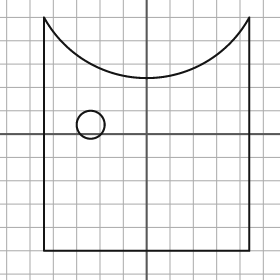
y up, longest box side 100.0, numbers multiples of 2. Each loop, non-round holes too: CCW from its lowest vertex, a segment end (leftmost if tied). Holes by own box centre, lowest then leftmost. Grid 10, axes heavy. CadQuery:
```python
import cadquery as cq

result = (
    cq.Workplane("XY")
    .moveTo(-44.0, -50.0)
    .lineTo(44.0, -50.0)
    .lineTo(44.0, 50.0)
    .threePointArc((0.0, 24.0), (-44.0, 50.0))
    .close()
    .moveTo(-24.0, 4.0)
    .circle(6.0)
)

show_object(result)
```